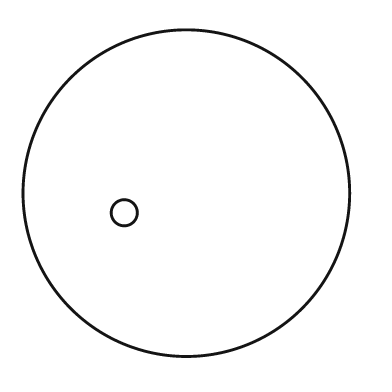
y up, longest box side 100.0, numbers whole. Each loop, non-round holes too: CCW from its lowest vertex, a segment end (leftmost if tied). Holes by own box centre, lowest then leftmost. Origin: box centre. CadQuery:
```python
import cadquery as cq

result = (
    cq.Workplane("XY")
    .moveTo(0.0, 0.0)
    .circle(50.0)
    .moveTo(-19.0, -6.0)
    .circle(4.0)
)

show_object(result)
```